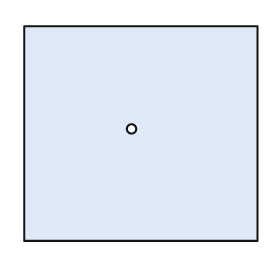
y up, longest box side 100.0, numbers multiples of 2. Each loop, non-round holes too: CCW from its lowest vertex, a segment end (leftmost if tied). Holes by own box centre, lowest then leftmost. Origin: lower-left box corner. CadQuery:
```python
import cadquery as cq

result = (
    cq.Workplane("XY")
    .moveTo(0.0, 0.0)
    .lineTo(100.0, 0.0)
    .lineTo(100.0, 92.0)
    .lineTo(0.0, 92.0)
    .close()
    .moveTo(46.0, 48.0)
    .circle(2.0)
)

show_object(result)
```